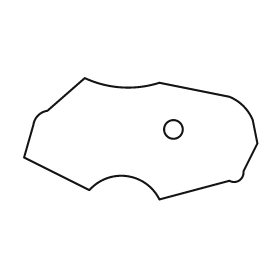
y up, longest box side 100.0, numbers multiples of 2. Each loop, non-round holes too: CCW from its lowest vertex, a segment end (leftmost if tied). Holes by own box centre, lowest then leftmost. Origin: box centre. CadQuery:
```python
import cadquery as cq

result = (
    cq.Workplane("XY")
    .moveTo(8.0, -26.0)
    .lineTo(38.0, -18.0)
    .threePointArc((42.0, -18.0), (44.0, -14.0))
    .lineTo(50.0, -2.0)
    .lineTo(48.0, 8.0)
    .threePointArc((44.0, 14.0), (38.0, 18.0))
    .lineTo(8.0, 24.0)
    .threePointArc((-8.0, 22.0), (-24.0, 26.0))
    .lineTo(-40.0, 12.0)
    .threePointArc((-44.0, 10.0), (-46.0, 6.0))
    .lineTo(-50.0, -8.0)
    .lineTo(-22.0, -22.0)
    .threePointArc((-6.0, -16.0), (8.0, -26.0))
    .close()
    .moveTo(14.0, 4.0)
    .circle(4.0)
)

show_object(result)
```